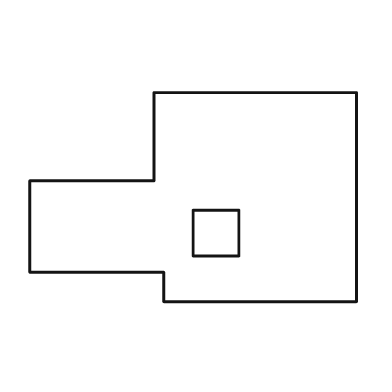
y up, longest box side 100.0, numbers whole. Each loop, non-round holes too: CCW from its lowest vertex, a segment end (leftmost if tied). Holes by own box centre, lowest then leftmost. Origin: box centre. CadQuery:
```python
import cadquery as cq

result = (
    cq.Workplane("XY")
    .moveTo(-9.0, -32.0)
    .lineTo(50.0, -32.0)
    .lineTo(50.0, 32.0)
    .lineTo(-12.0, 32.0)
    .lineTo(-12.0, 5.0)
    .lineTo(-50.0, 5.0)
    .lineTo(-50.0, -23.0)
    .lineTo(-9.0, -23.0)
    .close()
    .moveTo(0.0, -18.0)
    .lineTo(14.0, -18.0)
    .lineTo(14.0, -4.0)
    .lineTo(0.0, -4.0)
    .close()
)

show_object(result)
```